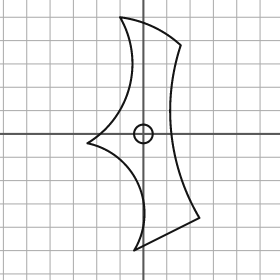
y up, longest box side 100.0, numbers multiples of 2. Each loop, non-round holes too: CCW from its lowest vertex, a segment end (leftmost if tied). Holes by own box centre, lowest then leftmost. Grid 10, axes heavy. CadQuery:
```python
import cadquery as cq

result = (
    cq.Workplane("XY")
    .moveTo(-4.0, -50.0)
    .lineTo(24.0, -36.0)
    .threePointArc((12.0, 0.0), (16.0, 38.0))
    .threePointArc((4.0, 46.0), (-10.0, 50.0))
    .threePointArc((-6.0, 20.0), (-24.0, -4.0))
    .threePointArc((-2.0, -22.0), (-4.0, -50.0))
    .close()
    .moveTo(0.0, 0.0)
    .circle(4.0)
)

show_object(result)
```